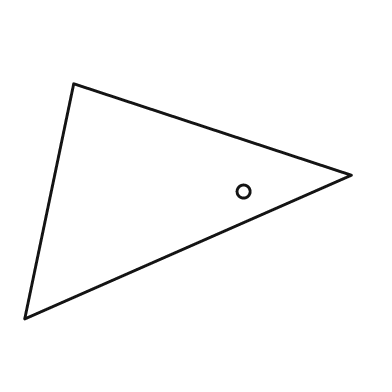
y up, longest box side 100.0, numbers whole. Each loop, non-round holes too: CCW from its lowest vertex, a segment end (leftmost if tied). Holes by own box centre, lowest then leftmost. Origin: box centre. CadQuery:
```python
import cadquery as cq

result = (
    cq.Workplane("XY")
    .moveTo(-50.0, -36.0)
    .lineTo(50.0, 8.0)
    .lineTo(-35.0, 36.0)
    .close()
    .moveTo(17.0, 3.0)
    .circle(2.0)
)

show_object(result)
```